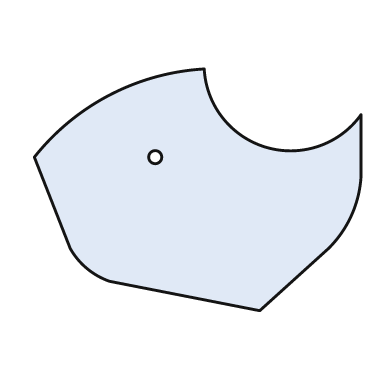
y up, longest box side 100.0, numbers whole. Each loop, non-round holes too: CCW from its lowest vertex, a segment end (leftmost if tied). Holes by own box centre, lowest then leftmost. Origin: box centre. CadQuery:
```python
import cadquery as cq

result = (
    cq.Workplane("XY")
    .moveTo(19.0, -37.0)
    .lineTo(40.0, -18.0)
    .threePointArc((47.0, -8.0), (50.0, 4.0))
    .lineTo(50.0, 23.0)
    .threePointArc((21.0, 13.0), (2.0, 37.0))
    .threePointArc((-27.0, 29.0), (-50.0, 10.0))
    .lineTo(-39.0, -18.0)
    .threePointArc((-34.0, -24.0), (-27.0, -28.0))
    .close()
    .moveTo(-13.0, 10.0)
    .circle(2.0)
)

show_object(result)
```